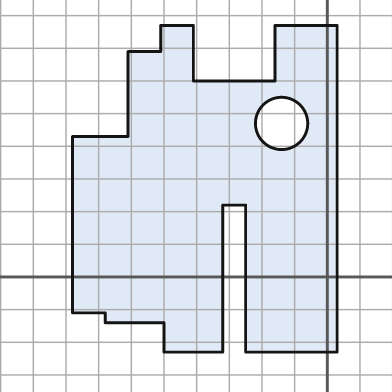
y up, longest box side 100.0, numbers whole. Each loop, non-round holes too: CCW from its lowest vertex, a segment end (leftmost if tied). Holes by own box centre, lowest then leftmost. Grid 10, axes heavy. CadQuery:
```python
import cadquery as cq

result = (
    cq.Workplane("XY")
    .moveTo(-50.0, -23.0)
    .lineTo(-32.0, -23.0)
    .lineTo(-32.0, 22.0)
    .lineTo(-25.0, 22.0)
    .lineTo(-25.0, -23.0)
    .lineTo(3.0, -23.0)
    .lineTo(3.0, 77.0)
    .lineTo(-16.0, 77.0)
    .lineTo(-16.0, 60.0)
    .lineTo(-41.0, 60.0)
    .lineTo(-41.0, 77.0)
    .lineTo(-51.0, 77.0)
    .lineTo(-51.0, 69.0)
    .lineTo(-61.0, 69.0)
    .lineTo(-61.0, 43.0)
    .lineTo(-78.0, 43.0)
    .lineTo(-78.0, -11.0)
    .lineTo(-68.0, -11.0)
    .lineTo(-68.0, -14.0)
    .lineTo(-50.0, -14.0)
    .close()
    .moveTo(-14.0, 47.0)
    .circle(8.0)
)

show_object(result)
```